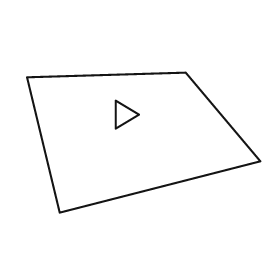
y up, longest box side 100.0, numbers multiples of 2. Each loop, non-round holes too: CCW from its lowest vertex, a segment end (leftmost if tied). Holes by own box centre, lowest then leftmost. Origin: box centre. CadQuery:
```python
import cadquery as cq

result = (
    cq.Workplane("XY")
    .moveTo(-36.0, -30.0)
    .lineTo(50.0, -8.0)
    .lineTo(18.0, 30.0)
    .lineTo(-50.0, 28.0)
    .close()
    .moveTo(-12.0, 6.0)
    .lineTo(-2.0, 12.0)
    .lineTo(-12.0, 18.0)
    .close()
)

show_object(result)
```